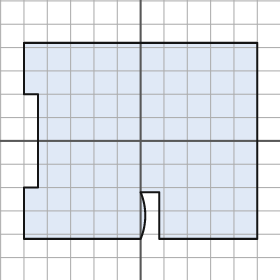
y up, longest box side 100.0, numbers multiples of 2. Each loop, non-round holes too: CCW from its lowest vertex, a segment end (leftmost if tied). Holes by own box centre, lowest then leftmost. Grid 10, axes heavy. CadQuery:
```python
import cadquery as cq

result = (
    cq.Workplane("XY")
    .moveTo(-50.0, -42.0)
    .lineTo(0.0, -42.0)
    .threePointArc((2.0, -32.0), (0.0, -22.0))
    .lineTo(8.0, -22.0)
    .lineTo(8.0, -42.0)
    .lineTo(50.0, -42.0)
    .lineTo(50.0, 42.0)
    .lineTo(-50.0, 42.0)
    .lineTo(-50.0, 20.0)
    .lineTo(-44.0, 20.0)
    .lineTo(-44.0, -20.0)
    .lineTo(-50.0, -20.0)
    .close()
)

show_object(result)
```